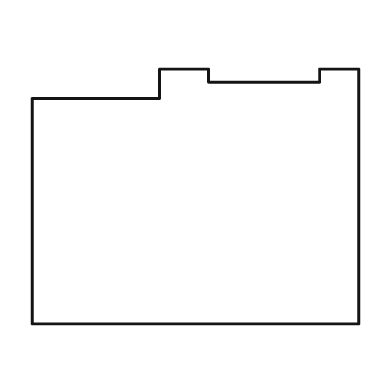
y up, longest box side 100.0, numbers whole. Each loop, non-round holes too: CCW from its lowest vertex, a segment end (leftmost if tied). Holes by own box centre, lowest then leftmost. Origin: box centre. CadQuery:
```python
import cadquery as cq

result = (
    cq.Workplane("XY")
    .moveTo(-50.0, -39.0)
    .lineTo(50.0, -39.0)
    .lineTo(50.0, 39.0)
    .lineTo(38.0, 39.0)
    .lineTo(38.0, 35.0)
    .lineTo(4.0, 35.0)
    .lineTo(4.0, 39.0)
    .lineTo(-11.0, 39.0)
    .lineTo(-11.0, 30.0)
    .lineTo(-50.0, 30.0)
    .close()
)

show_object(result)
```